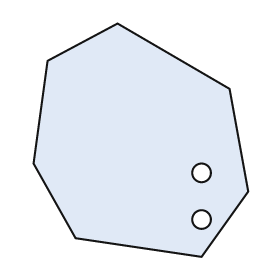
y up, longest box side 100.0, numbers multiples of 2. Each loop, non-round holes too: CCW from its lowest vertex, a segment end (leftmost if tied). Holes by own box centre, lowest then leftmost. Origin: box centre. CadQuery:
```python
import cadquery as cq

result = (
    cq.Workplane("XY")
    .moveTo(26.0, -50.0)
    .lineTo(46.0, -22.0)
    .lineTo(38.0, 22.0)
    .lineTo(-10.0, 50.0)
    .lineTo(-40.0, 34.0)
    .lineTo(-46.0, -10.0)
    .lineTo(-28.0, -42.0)
    .close()
    .moveTo(26.0, -34.0)
    .circle(4.0)
    .moveTo(26.0, -14.0)
    .circle(4.0)
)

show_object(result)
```